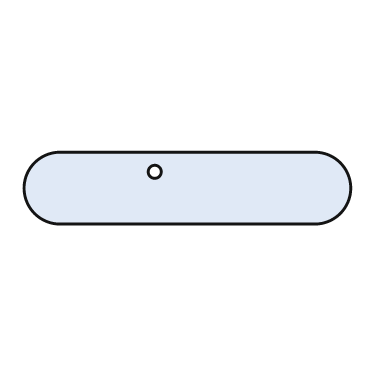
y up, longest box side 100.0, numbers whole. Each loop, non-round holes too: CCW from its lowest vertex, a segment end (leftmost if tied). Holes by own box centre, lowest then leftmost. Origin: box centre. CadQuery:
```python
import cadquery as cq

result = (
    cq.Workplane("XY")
    .moveTo(-39.0, -11.0)
    .lineTo(39.0, -11.0)
    .threePointArc((50.0, 0.0), (39.0, 11.0))
    .lineTo(-39.0, 11.0)
    .threePointArc((-50.0, 0.0), (-39.0, -11.0))
    .close()
    .moveTo(-10.0, 5.0)
    .circle(2.0)
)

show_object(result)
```